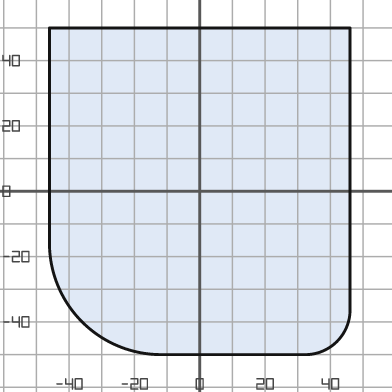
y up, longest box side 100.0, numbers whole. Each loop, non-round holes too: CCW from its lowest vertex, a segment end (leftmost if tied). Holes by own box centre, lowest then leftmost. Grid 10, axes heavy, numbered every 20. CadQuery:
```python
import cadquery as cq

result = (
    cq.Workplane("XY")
    .moveTo(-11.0, -50.0)
    .lineTo(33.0, -50.0)
    .threePointArc((42.0, -46.0), (46.0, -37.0))
    .lineTo(46.0, 50.0)
    .lineTo(-46.0, 50.0)
    .lineTo(-46.0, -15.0)
    .threePointArc((-36.0, -40.0), (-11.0, -50.0))
    .close()
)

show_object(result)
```